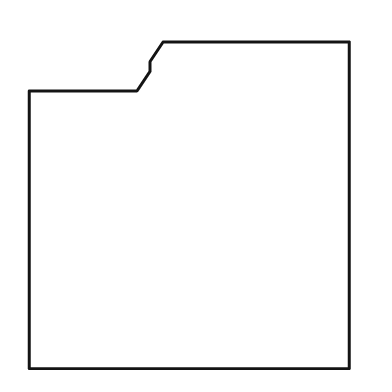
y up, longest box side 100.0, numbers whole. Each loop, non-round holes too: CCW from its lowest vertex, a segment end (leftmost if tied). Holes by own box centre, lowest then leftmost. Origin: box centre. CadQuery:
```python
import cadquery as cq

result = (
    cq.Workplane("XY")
    .moveTo(-49.0, -50.0)
    .lineTo(49.0, -50.0)
    .lineTo(49.0, 50.0)
    .lineTo(-8.0, 50.0)
    .lineTo(-12.0, 44.0)
    .lineTo(-12.0, 41.0)
    .lineTo(-16.0, 35.0)
    .lineTo(-49.0, 35.0)
    .close()
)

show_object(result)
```